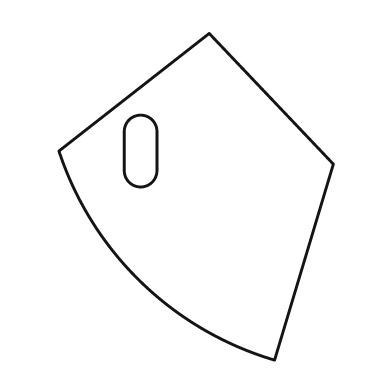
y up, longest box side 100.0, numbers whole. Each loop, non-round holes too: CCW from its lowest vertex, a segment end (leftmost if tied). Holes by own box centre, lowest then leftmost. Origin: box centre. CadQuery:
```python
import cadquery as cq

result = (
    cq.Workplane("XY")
    .moveTo(24.0, -50.0)
    .lineTo(42.0, 10.0)
    .lineTo(4.0, 50.0)
    .lineTo(-42.0, 14.0)
    .threePointArc((-17.0, -26.0), (24.0, -50.0))
    .close()
    .moveTo(-22.0, 8.0)
    .threePointArc((-17.0, 3.0), (-12.0, 8.0))
    .lineTo(-12.0, 20.0)
    .threePointArc((-17.0, 25.0), (-22.0, 20.0))
    .close()
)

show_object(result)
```